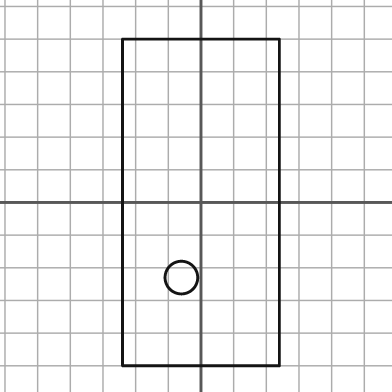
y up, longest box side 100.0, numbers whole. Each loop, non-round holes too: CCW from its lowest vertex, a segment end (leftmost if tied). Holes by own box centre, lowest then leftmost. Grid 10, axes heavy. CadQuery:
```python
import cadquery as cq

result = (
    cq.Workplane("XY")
    .moveTo(-24.0, -50.0)
    .lineTo(24.0, -50.0)
    .lineTo(24.0, 50.0)
    .lineTo(-24.0, 50.0)
    .close()
    .moveTo(-6.0, -23.0)
    .circle(5.0)
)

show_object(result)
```